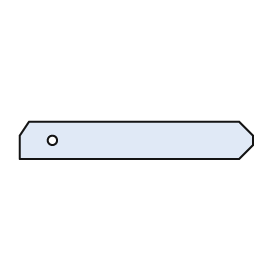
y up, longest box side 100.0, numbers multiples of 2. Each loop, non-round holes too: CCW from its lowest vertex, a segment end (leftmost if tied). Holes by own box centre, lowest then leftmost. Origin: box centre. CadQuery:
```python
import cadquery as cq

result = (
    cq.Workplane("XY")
    .moveTo(-50.0, -8.0)
    .lineTo(44.0, -8.0)
    .lineTo(50.0, -2.0)
    .lineTo(50.0, 2.0)
    .lineTo(44.0, 8.0)
    .lineTo(-46.0, 8.0)
    .lineTo(-50.0, 2.0)
    .close()
    .moveTo(-36.0, 0.0)
    .circle(2.0)
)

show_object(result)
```